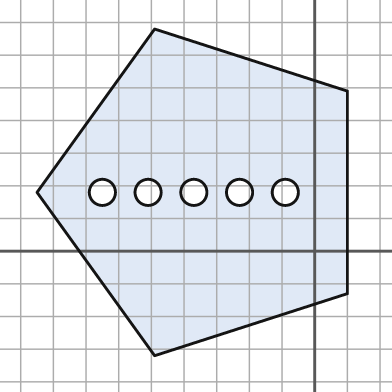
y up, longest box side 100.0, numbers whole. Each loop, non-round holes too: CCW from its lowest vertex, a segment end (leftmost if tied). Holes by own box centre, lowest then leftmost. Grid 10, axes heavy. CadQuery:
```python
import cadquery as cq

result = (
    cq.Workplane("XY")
    .moveTo(-49.0, -32.0)
    .lineTo(10.0, -13.0)
    .lineTo(10.0, 49.0)
    .lineTo(-49.0, 68.0)
    .lineTo(-85.0, 18.0)
    .close()
    .moveTo(-65.0, 18.0)
    .circle(4.0)
    .moveTo(-51.0, 18.0)
    .circle(4.0)
    .moveTo(-37.0, 18.0)
    .circle(4.0)
    .moveTo(-23.0, 18.0)
    .circle(4.0)
    .moveTo(-9.0, 18.0)
    .circle(4.0)
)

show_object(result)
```